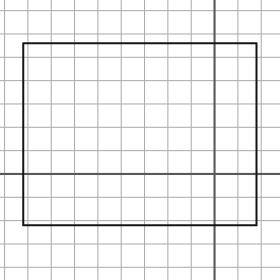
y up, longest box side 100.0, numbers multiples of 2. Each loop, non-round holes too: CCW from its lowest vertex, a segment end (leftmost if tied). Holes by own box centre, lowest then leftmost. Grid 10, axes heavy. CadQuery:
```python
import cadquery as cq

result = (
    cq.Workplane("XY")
    .moveTo(-82.0, -22.0)
    .lineTo(18.0, -22.0)
    .lineTo(18.0, 56.0)
    .lineTo(-82.0, 56.0)
    .close()
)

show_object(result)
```